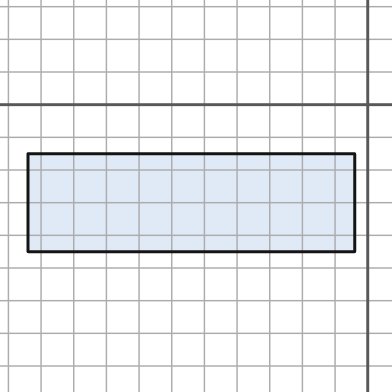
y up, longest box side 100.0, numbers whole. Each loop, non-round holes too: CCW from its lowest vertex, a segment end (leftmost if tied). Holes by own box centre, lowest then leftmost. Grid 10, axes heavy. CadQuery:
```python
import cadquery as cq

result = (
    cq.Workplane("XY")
    .moveTo(-104.0, -45.0)
    .lineTo(-4.0, -45.0)
    .lineTo(-4.0, -15.0)
    .lineTo(-104.0, -15.0)
    .close()
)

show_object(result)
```